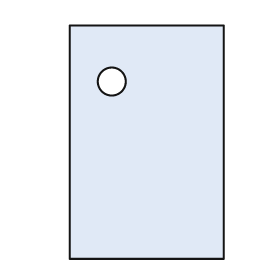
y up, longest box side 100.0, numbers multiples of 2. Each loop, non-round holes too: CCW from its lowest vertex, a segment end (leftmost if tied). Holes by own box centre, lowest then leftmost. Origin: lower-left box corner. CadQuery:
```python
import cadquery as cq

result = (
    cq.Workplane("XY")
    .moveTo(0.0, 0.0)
    .lineTo(66.0, 0.0)
    .lineTo(66.0, 100.0)
    .lineTo(0.0, 100.0)
    .close()
    .moveTo(18.0, 76.0)
    .circle(6.0)
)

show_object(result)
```